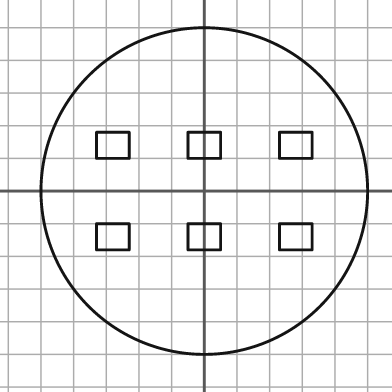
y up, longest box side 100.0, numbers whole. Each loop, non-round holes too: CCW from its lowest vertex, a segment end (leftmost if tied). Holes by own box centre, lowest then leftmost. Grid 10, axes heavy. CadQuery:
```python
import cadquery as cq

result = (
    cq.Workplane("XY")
    .moveTo(0.0, 0.0)
    .circle(50.0)
    .moveTo(-33.0, -18.0)
    .lineTo(-23.0, -18.0)
    .lineTo(-23.0, -10.0)
    .lineTo(-33.0, -10.0)
    .close()
    .moveTo(-5.0, -18.0)
    .lineTo(5.0, -18.0)
    .lineTo(5.0, -10.0)
    .lineTo(-5.0, -10.0)
    .close()
    .moveTo(23.0, -18.0)
    .lineTo(33.0, -18.0)
    .lineTo(33.0, -10.0)
    .lineTo(23.0, -10.0)
    .close()
    .moveTo(-33.0, 10.0)
    .lineTo(-23.0, 10.0)
    .lineTo(-23.0, 18.0)
    .lineTo(-33.0, 18.0)
    .close()
    .moveTo(-5.0, 10.0)
    .lineTo(5.0, 10.0)
    .lineTo(5.0, 18.0)
    .lineTo(-5.0, 18.0)
    .close()
    .moveTo(23.0, 10.0)
    .lineTo(33.0, 10.0)
    .lineTo(33.0, 18.0)
    .lineTo(23.0, 18.0)
    .close()
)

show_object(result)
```